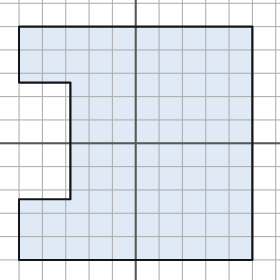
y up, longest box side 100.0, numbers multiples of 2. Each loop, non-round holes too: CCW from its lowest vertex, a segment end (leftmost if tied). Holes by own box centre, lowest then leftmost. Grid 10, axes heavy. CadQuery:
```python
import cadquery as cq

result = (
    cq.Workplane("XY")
    .moveTo(-50.0, -50.0)
    .lineTo(50.0, -50.0)
    .lineTo(50.0, 50.0)
    .lineTo(-50.0, 50.0)
    .lineTo(-50.0, 26.0)
    .lineTo(-28.0, 26.0)
    .lineTo(-28.0, -24.0)
    .lineTo(-50.0, -24.0)
    .close()
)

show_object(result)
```